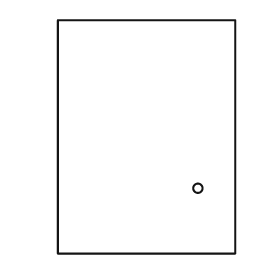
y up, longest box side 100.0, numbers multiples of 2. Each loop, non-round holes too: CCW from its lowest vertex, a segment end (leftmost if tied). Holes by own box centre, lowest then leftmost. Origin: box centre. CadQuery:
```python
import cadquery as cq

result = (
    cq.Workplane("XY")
    .moveTo(-38.0, -50.0)
    .lineTo(38.0, -50.0)
    .lineTo(38.0, 50.0)
    .lineTo(-38.0, 50.0)
    .close()
    .moveTo(22.0, -22.0)
    .circle(2.0)
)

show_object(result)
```